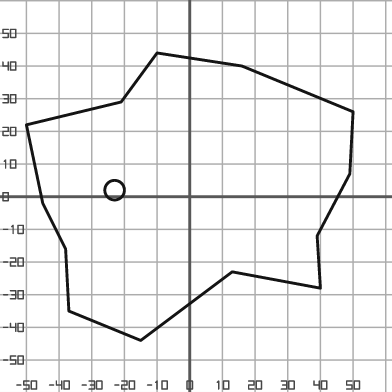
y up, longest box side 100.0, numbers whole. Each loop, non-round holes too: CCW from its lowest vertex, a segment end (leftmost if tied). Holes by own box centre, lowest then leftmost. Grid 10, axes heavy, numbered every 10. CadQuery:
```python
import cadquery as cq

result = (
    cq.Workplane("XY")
    .moveTo(-15.0, -44.0)
    .lineTo(13.0, -23.0)
    .lineTo(40.0, -28.0)
    .lineTo(39.0, -12.0)
    .lineTo(49.0, 7.0)
    .lineTo(50.0, 26.0)
    .lineTo(16.0, 40.0)
    .lineTo(-10.0, 44.0)
    .lineTo(-21.0, 29.0)
    .lineTo(-50.0, 22.0)
    .lineTo(-45.0, -2.0)
    .lineTo(-38.0, -16.0)
    .lineTo(-37.0, -35.0)
    .close()
    .moveTo(-23.0, 2.0)
    .circle(3.0)
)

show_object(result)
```